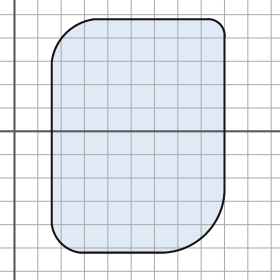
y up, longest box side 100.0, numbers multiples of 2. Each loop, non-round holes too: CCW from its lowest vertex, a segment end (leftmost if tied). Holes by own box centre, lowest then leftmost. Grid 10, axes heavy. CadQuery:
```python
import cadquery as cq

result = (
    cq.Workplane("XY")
    .moveTo(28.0, -52.0)
    .lineTo(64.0, -52.0)
    .threePointArc((82.0, -44.0), (90.0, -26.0))
    .lineTo(90.0, 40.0)
    .threePointArc((88.0, 46.0), (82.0, 48.0))
    .lineTo(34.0, 48.0)
    .threePointArc((22.0, 42.0), (16.0, 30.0))
    .lineTo(16.0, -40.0)
    .threePointArc((20.0, -48.0), (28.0, -52.0))
    .close()
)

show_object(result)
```